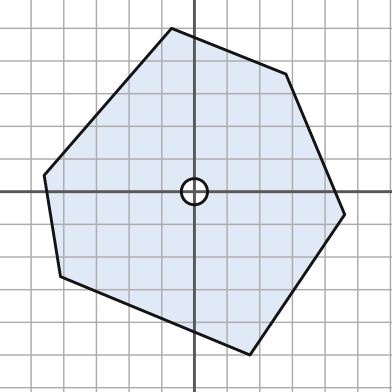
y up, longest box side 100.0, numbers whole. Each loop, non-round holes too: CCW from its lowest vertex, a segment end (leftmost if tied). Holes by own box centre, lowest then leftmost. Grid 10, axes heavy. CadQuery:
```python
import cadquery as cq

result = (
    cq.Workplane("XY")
    .moveTo(17.0, -50.0)
    .lineTo(46.0, -7.0)
    .lineTo(28.0, 36.0)
    .lineTo(-7.0, 50.0)
    .lineTo(-46.0, 5.0)
    .lineTo(-41.0, -26.0)
    .close()
    .moveTo(0.0, 0.0)
    .circle(4.0)
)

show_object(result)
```